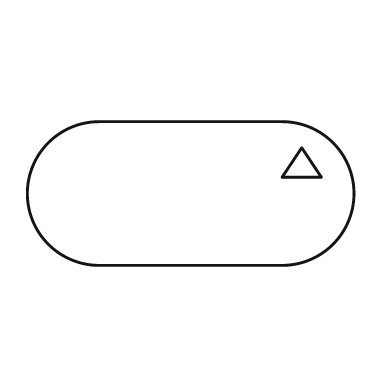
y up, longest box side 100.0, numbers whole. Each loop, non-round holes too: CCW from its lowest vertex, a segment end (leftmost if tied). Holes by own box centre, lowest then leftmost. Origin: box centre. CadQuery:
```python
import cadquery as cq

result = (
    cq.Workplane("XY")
    .moveTo(-28.0, -22.0)
    .lineTo(28.0, -22.0)
    .threePointArc((50.0, 0.0), (28.0, 22.0))
    .lineTo(-28.0, 22.0)
    .threePointArc((-50.0, 0.0), (-28.0, -22.0))
    .close()
    .moveTo(28.0, 5.0)
    .lineTo(40.0, 5.0)
    .lineTo(34.0, 14.0)
    .close()
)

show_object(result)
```